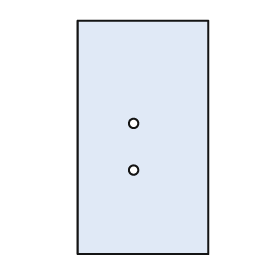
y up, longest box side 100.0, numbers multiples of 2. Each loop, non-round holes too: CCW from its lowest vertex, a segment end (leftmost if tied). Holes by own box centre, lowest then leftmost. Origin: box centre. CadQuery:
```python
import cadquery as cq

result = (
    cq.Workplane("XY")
    .moveTo(-28.0, -50.0)
    .lineTo(28.0, -50.0)
    .lineTo(28.0, 50.0)
    .lineTo(-28.0, 50.0)
    .close()
    .moveTo(-4.0, -14.0)
    .circle(2.0)
    .moveTo(-4.0, 6.0)
    .circle(2.0)
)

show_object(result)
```